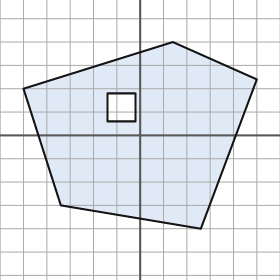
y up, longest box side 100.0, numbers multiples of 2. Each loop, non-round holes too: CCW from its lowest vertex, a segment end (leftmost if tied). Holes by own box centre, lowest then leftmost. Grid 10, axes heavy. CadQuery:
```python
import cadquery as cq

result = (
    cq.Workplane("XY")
    .moveTo(26.0, -40.0)
    .lineTo(50.0, 24.0)
    .lineTo(14.0, 40.0)
    .lineTo(-50.0, 20.0)
    .lineTo(-34.0, -30.0)
    .close()
    .moveTo(-14.0, 6.0)
    .lineTo(-2.0, 6.0)
    .lineTo(-2.0, 18.0)
    .lineTo(-14.0, 18.0)
    .close()
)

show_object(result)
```